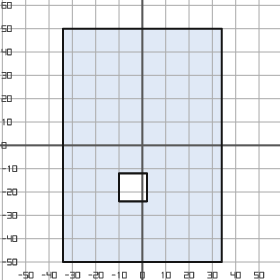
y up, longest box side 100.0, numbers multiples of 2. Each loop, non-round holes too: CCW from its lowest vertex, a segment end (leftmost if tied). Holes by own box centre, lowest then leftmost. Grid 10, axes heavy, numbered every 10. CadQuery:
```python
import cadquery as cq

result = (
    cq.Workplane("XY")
    .moveTo(-34.0, -50.0)
    .lineTo(34.0, -50.0)
    .lineTo(34.0, 50.0)
    .lineTo(-34.0, 50.0)
    .close()
    .moveTo(-10.0, -24.0)
    .lineTo(2.0, -24.0)
    .lineTo(2.0, -12.0)
    .lineTo(-10.0, -12.0)
    .close()
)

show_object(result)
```